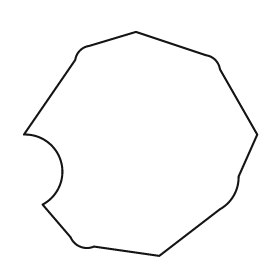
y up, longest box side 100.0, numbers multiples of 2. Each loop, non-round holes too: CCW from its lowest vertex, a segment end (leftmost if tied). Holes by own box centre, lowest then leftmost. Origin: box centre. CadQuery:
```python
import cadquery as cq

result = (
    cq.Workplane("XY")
    .moveTo(8.0, -48.0)
    .lineTo(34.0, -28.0)
    .threePointArc((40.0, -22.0), (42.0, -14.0))
    .lineTo(50.0, 4.0)
    .lineTo(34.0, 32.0)
    .threePointArc((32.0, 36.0), (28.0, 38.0))
    .lineTo(-2.0, 48.0)
    .lineTo(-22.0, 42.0)
    .threePointArc((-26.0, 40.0), (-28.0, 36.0))
    .lineTo(-50.0, 4.0)
    .threePointArc((-34.0, -8.0), (-42.0, -26.0))
    .lineTo(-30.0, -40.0)
    .threePointArc((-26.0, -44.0), (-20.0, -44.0))
    .close()
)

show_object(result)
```